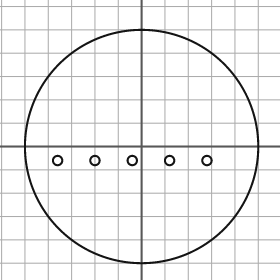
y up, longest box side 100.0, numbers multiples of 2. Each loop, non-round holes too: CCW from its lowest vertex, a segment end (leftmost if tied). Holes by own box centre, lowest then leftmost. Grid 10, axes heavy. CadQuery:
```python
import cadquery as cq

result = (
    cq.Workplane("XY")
    .moveTo(0.0, 0.0)
    .circle(50.0)
    .moveTo(-36.0, -6.0)
    .circle(2.0)
    .moveTo(-20.0, -6.0)
    .circle(2.0)
    .moveTo(-4.0, -6.0)
    .circle(2.0)
    .moveTo(12.0, -6.0)
    .circle(2.0)
    .moveTo(28.0, -6.0)
    .circle(2.0)
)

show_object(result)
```